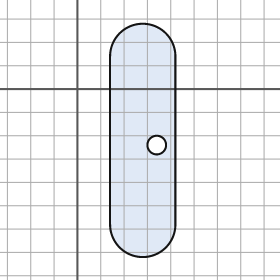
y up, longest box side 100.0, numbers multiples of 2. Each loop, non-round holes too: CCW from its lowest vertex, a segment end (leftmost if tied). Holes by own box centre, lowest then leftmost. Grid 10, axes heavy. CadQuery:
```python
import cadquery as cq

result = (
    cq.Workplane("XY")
    .moveTo(14.0, -58.0)
    .threePointArc((28.0, -72.0), (42.0, -58.0))
    .lineTo(42.0, 14.0)
    .threePointArc((28.0, 28.0), (14.0, 14.0))
    .close()
    .moveTo(34.0, -24.0)
    .circle(4.0)
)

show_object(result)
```